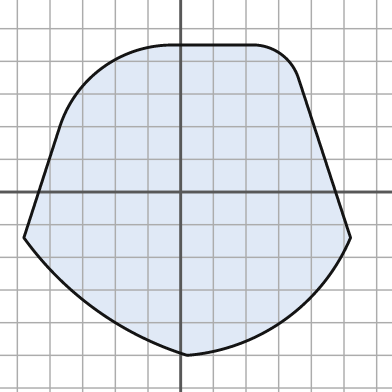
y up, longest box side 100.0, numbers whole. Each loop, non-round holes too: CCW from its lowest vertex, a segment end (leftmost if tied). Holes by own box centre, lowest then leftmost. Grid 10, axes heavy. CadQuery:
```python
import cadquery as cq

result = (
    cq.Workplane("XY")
    .moveTo(2.0, -50.0)
    .threePointArc((32.0, -39.0), (52.0, -14.0))
    .lineTo(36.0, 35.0)
    .threePointArc((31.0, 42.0), (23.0, 45.0))
    .lineTo(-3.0, 45.0)
    .threePointArc((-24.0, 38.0), (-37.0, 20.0))
    .lineTo(-48.0, -14.0)
    .threePointArc((-26.0, -36.0), (2.0, -50.0))
    .close()
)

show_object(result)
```